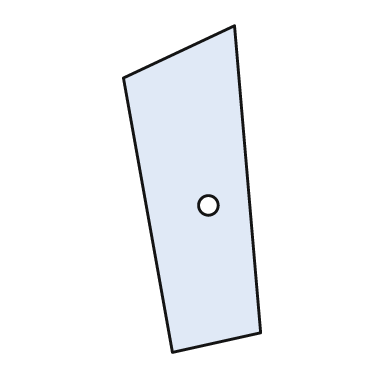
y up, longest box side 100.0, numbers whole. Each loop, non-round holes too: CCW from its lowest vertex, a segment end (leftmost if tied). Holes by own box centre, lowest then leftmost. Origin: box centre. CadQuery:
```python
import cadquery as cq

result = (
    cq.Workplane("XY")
    .moveTo(-6.0, -50.0)
    .lineTo(21.0, -44.0)
    .lineTo(13.0, 50.0)
    .lineTo(-21.0, 34.0)
    .close()
    .moveTo(5.0, -5.0)
    .circle(3.0)
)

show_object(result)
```